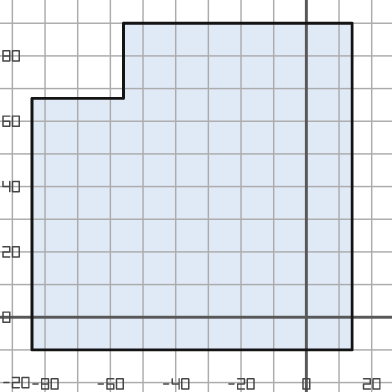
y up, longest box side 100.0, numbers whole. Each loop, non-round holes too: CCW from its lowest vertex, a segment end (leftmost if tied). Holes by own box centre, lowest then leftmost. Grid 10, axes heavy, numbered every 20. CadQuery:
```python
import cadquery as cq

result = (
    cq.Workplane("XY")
    .moveTo(-84.0, -10.0)
    .lineTo(14.0, -10.0)
    .lineTo(14.0, 90.0)
    .lineTo(-56.0, 90.0)
    .lineTo(-56.0, 67.0)
    .lineTo(-84.0, 67.0)
    .close()
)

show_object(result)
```